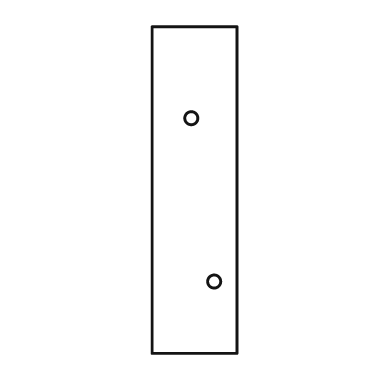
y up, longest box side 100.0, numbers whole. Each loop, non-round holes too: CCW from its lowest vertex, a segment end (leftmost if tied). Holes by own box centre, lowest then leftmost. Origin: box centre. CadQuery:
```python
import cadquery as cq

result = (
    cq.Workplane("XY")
    .moveTo(-13.0, -50.0)
    .lineTo(13.0, -50.0)
    .lineTo(13.0, 50.0)
    .lineTo(-13.0, 50.0)
    .close()
    .moveTo(6.0, -28.0)
    .circle(2.0)
    .moveTo(-1.0, 22.0)
    .circle(2.0)
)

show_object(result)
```